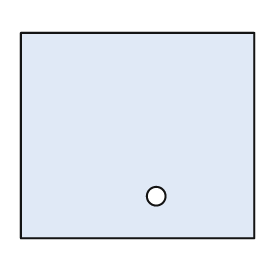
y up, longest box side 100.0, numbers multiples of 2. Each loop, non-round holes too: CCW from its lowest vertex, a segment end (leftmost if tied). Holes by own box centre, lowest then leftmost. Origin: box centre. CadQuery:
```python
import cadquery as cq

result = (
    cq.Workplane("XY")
    .moveTo(-50.0, -44.0)
    .lineTo(50.0, -44.0)
    .lineTo(50.0, 44.0)
    .lineTo(-50.0, 44.0)
    .close()
    .moveTo(8.0, -26.0)
    .circle(4.0)
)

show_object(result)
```